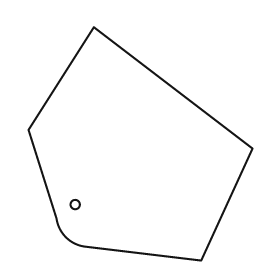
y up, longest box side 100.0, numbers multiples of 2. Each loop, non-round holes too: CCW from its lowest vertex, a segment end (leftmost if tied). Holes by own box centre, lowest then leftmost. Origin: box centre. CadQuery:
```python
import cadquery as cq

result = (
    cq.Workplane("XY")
    .moveTo(26.0, -50.0)
    .lineTo(48.0, -2.0)
    .lineTo(-20.0, 50.0)
    .lineTo(-48.0, 6.0)
    .lineTo(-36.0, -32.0)
    .threePointArc((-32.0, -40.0), (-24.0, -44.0))
    .close()
    .moveTo(-28.0, -26.0)
    .circle(2.0)
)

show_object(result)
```